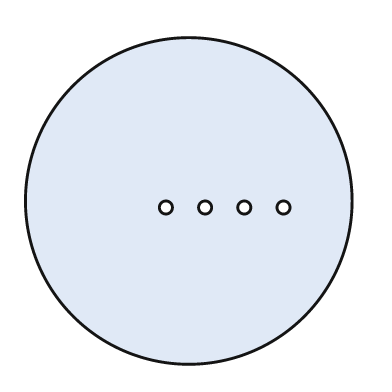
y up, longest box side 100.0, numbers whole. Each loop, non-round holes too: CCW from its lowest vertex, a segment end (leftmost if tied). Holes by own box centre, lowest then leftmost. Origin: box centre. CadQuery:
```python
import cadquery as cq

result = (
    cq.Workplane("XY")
    .moveTo(0.0, 0.0)
    .circle(50.0)
    .moveTo(-7.0, -2.0)
    .circle(2.0)
    .moveTo(5.0, -2.0)
    .circle(2.0)
    .moveTo(17.0, -2.0)
    .circle(2.0)
    .moveTo(29.0, -2.0)
    .circle(2.0)
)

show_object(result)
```